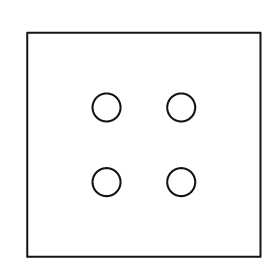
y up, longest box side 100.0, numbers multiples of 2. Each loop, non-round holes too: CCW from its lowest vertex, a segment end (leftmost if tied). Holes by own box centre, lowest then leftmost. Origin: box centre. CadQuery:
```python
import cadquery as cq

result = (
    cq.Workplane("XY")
    .moveTo(-50.0, -48.0)
    .lineTo(50.0, -48.0)
    .lineTo(50.0, 48.0)
    .lineTo(-50.0, 48.0)
    .close()
    .moveTo(-16.0, -16.0)
    .circle(6.0)
    .moveTo(16.0, -16.0)
    .circle(6.0)
    .moveTo(-16.0, 16.0)
    .circle(6.0)
    .moveTo(16.0, 16.0)
    .circle(6.0)
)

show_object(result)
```